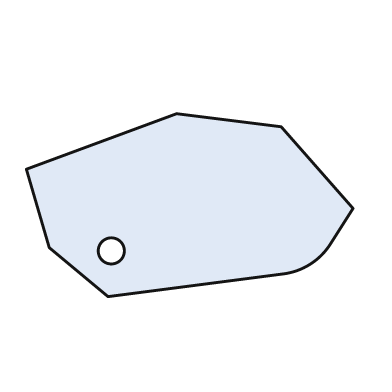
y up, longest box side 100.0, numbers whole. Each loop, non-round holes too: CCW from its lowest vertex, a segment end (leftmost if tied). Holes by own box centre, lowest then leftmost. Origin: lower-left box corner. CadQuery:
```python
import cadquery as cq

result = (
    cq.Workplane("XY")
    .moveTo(25.0, 0.0)
    .lineTo(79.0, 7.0)
    .threePointArc((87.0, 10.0), (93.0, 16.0))
    .lineTo(100.0, 27.0)
    .lineTo(78.0, 52.0)
    .lineTo(46.0, 56.0)
    .lineTo(0.0, 39.0)
    .lineTo(7.0, 15.0)
    .close()
    .moveTo(26.0, 14.0)
    .circle(4.0)
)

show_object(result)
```